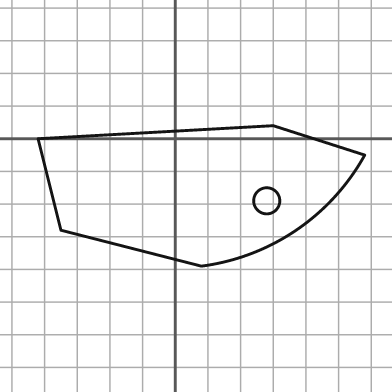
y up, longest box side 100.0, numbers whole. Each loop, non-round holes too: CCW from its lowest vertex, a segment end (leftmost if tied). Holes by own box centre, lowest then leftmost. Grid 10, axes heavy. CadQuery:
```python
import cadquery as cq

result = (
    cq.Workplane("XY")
    .moveTo(8.0, -39.0)
    .threePointArc((37.0, -28.0), (58.0, -5.0))
    .lineTo(30.0, 4.0)
    .lineTo(-42.0, 0.0)
    .lineTo(-35.0, -28.0)
    .close()
    .moveTo(28.0, -19.0)
    .circle(4.0)
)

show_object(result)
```